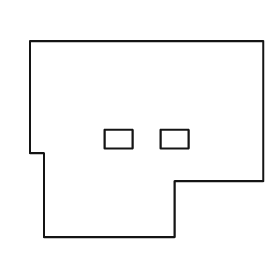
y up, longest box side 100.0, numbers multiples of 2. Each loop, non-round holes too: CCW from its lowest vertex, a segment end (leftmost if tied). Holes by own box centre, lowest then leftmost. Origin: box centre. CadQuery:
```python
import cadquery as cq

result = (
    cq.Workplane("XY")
    .moveTo(-44.0, -42.0)
    .lineTo(12.0, -42.0)
    .lineTo(12.0, -18.0)
    .lineTo(50.0, -18.0)
    .lineTo(50.0, 42.0)
    .lineTo(-50.0, 42.0)
    .lineTo(-50.0, -6.0)
    .lineTo(-44.0, -6.0)
    .close()
    .moveTo(-18.0, -4.0)
    .lineTo(-6.0, -4.0)
    .lineTo(-6.0, 4.0)
    .lineTo(-18.0, 4.0)
    .close()
    .moveTo(6.0, -4.0)
    .lineTo(18.0, -4.0)
    .lineTo(18.0, 4.0)
    .lineTo(6.0, 4.0)
    .close()
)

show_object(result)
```